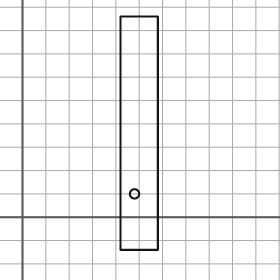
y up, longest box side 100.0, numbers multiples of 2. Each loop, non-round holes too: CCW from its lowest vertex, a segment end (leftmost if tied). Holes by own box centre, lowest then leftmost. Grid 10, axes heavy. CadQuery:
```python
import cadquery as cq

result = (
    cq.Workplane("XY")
    .moveTo(42.0, -14.0)
    .lineTo(58.0, -14.0)
    .lineTo(58.0, 86.0)
    .lineTo(42.0, 86.0)
    .close()
    .moveTo(48.0, 10.0)
    .circle(2.0)
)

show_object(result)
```